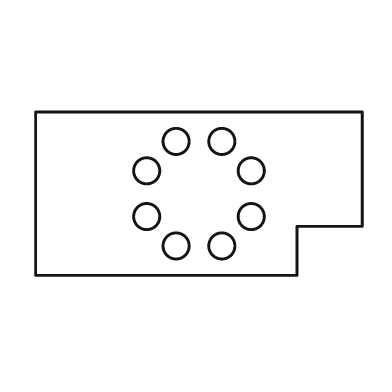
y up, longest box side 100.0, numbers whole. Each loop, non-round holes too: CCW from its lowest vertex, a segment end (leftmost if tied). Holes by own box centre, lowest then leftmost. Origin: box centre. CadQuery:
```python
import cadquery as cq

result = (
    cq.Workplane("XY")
    .moveTo(-50.0, -25.0)
    .lineTo(30.0, -25.0)
    .lineTo(30.0, -10.0)
    .lineTo(50.0, -10.0)
    .lineTo(50.0, 25.0)
    .lineTo(-50.0, 25.0)
    .close()
    .moveTo(-7.0, -16.0)
    .circle(4.0)
    .moveTo(7.0, -16.0)
    .circle(4.0)
    .moveTo(-16.0, -7.0)
    .circle(4.0)
    .moveTo(16.0, -7.0)
    .circle(4.0)
    .moveTo(-16.0, 7.0)
    .circle(4.0)
    .moveTo(16.0, 7.0)
    .circle(4.0)
    .moveTo(-7.0, 16.0)
    .circle(4.0)
    .moveTo(7.0, 16.0)
    .circle(4.0)
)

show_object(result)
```